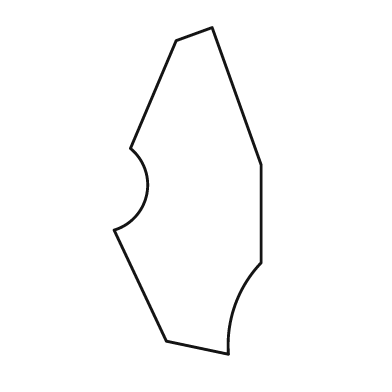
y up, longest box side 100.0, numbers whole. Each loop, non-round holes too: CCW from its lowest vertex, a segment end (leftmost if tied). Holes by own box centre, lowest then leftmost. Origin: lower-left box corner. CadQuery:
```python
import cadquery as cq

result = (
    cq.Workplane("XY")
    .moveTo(35.0, 0.0)
    .threePointArc((37.0, 15.0), (45.0, 28.0))
    .lineTo(45.0, 58.0)
    .lineTo(30.0, 100.0)
    .lineTo(19.0, 96.0)
    .lineTo(5.0, 63.0)
    .threePointArc((10.0, 49.0), (0.0, 38.0))
    .lineTo(16.0, 4.0)
    .close()
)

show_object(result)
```